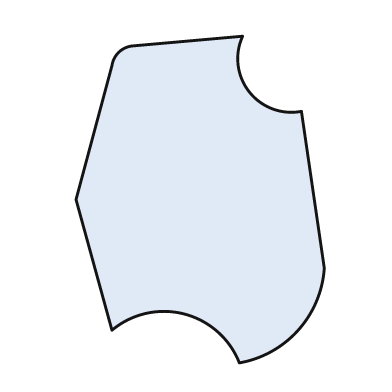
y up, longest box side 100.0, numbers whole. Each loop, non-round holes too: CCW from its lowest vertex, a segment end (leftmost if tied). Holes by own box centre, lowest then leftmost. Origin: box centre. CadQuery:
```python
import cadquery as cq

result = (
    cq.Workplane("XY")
    .moveTo(12.0, -50.0)
    .threePointArc((30.0, -40.0), (38.0, -21.0))
    .lineTo(31.0, 27.0)
    .threePointArc((15.0, 33.0), (13.0, 50.0))
    .lineTo(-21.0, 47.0)
    .threePointArc((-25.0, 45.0), (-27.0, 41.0))
    .lineTo(-38.0, 0.0)
    .lineTo(-27.0, -40.0)
    .threePointArc((-5.0, -35.0), (12.0, -50.0))
    .close()
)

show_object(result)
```